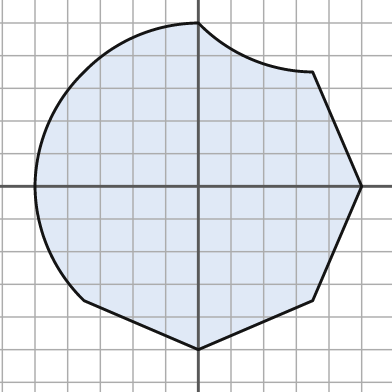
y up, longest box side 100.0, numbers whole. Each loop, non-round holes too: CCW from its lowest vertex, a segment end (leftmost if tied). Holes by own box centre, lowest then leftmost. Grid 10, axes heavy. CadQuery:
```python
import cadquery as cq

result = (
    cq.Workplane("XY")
    .moveTo(0.0, -50.0)
    .lineTo(35.0, -35.0)
    .lineTo(50.0, 0.0)
    .lineTo(35.0, 35.0)
    .threePointArc((16.0, 39.0), (0.0, 50.0))
    .threePointArc((-19.0, 46.0), (-35.0, 35.0))
    .threePointArc((-46.0, 19.0), (-50.0, 0.0))
    .threePointArc((-46.0, -19.0), (-35.0, -35.0))
    .close()
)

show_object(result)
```